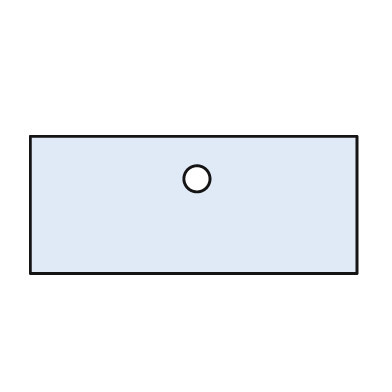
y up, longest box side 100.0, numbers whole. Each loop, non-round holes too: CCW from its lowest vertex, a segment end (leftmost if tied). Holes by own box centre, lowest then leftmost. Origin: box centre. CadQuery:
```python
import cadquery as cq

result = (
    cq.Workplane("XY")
    .moveTo(-50.0, -21.0)
    .lineTo(50.0, -21.0)
    .lineTo(50.0, 21.0)
    .lineTo(-50.0, 21.0)
    .close()
    .moveTo(1.0, 8.0)
    .circle(4.0)
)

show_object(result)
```